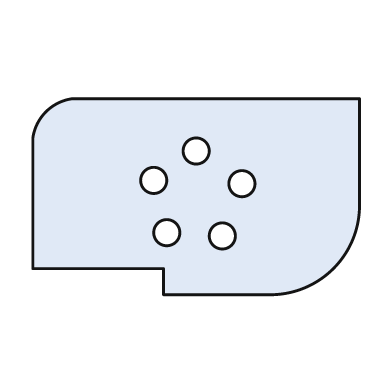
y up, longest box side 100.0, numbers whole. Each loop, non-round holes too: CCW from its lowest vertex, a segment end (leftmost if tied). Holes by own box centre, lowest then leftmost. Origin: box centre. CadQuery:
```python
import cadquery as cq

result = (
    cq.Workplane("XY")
    .moveTo(-10.0, -30.0)
    .lineTo(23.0, -30.0)
    .threePointArc((42.0, -22.0), (50.0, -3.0))
    .lineTo(50.0, 30.0)
    .lineTo(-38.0, 30.0)
    .threePointArc((-46.0, 26.0), (-50.0, 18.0))
    .lineTo(-50.0, -22.0)
    .lineTo(-10.0, -22.0)
    .close()
    .moveTo(8.0, -12.0)
    .circle(4.0)
    .moveTo(-9.0, -11.0)
    .circle(4.0)
    .moveTo(14.0, 4.0)
    .circle(4.0)
    .moveTo(-13.0, 5.0)
    .circle(4.0)
    .moveTo(0.0, 14.0)
    .circle(4.0)
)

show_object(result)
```